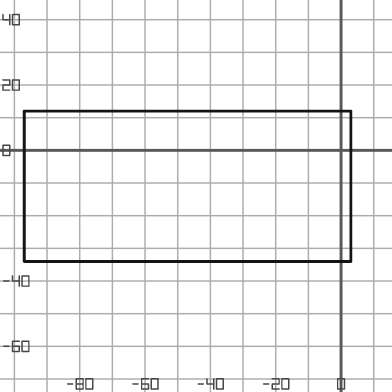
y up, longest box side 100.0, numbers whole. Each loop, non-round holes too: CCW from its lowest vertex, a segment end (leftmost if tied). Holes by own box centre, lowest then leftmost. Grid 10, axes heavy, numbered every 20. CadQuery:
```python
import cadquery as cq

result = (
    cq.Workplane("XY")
    .moveTo(-97.0, -34.0)
    .lineTo(3.0, -34.0)
    .lineTo(3.0, 12.0)
    .lineTo(-97.0, 12.0)
    .close()
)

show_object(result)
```